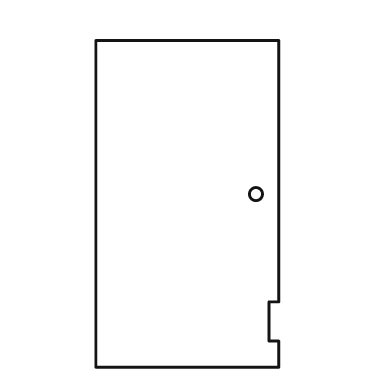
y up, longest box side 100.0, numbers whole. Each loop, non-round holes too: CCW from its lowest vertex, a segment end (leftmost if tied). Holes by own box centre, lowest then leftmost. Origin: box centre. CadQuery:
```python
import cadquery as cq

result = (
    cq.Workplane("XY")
    .moveTo(-28.0, -50.0)
    .lineTo(28.0, -50.0)
    .lineTo(28.0, -42.0)
    .lineTo(25.0, -42.0)
    .lineTo(25.0, -30.0)
    .lineTo(28.0, -30.0)
    .lineTo(28.0, 50.0)
    .lineTo(-28.0, 50.0)
    .close()
    .moveTo(21.0, 3.0)
    .circle(2.0)
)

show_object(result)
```